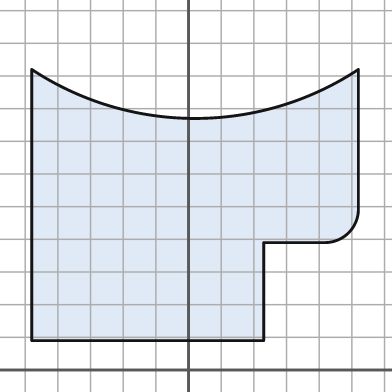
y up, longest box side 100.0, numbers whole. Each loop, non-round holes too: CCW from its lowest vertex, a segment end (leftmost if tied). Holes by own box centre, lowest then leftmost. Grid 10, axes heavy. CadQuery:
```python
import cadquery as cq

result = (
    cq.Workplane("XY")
    .moveTo(-48.0, 9.0)
    .lineTo(23.0, 9.0)
    .lineTo(23.0, 39.0)
    .lineTo(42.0, 39.0)
    .threePointArc((49.0, 42.0), (52.0, 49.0))
    .lineTo(52.0, 92.0)
    .threePointArc((2.0, 77.0), (-48.0, 92.0))
    .close()
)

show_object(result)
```